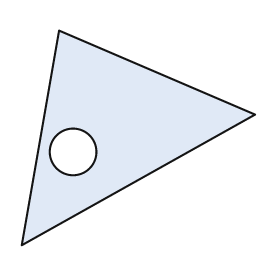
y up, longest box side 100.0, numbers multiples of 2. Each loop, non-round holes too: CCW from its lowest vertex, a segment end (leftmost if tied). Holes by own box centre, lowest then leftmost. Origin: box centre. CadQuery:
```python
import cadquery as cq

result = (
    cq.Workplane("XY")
    .moveTo(-50.0, -46.0)
    .lineTo(50.0, 10.0)
    .lineTo(-34.0, 46.0)
    .close()
    .moveTo(-28.0, -6.0)
    .circle(10.0)
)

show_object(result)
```